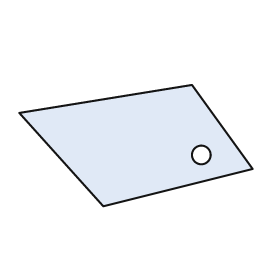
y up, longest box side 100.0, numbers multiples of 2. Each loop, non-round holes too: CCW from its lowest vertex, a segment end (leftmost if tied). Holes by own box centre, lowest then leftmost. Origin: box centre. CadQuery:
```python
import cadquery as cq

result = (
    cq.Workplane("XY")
    .moveTo(-14.0, -26.0)
    .lineTo(50.0, -10.0)
    .lineTo(24.0, 26.0)
    .lineTo(-50.0, 14.0)
    .close()
    .moveTo(28.0, -4.0)
    .circle(4.0)
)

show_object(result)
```